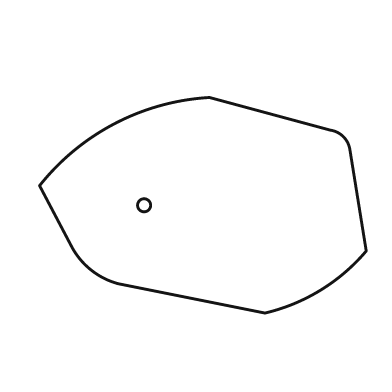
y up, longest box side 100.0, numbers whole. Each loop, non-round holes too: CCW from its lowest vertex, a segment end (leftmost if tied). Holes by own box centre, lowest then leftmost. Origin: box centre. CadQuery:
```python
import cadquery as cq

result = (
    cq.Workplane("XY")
    .moveTo(19.0, -33.0)
    .threePointArc((36.0, -26.0), (50.0, -14.0))
    .lineTo(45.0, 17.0)
    .threePointArc((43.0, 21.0), (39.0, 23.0))
    .lineTo(2.0, 33.0)
    .threePointArc((-27.0, 25.0), (-50.0, 6.0))
    .lineTo(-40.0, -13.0)
    .threePointArc((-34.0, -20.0), (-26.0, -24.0))
    .close()
    .moveTo(-18.0, 0.0)
    .circle(2.0)
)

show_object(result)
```